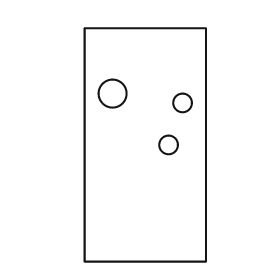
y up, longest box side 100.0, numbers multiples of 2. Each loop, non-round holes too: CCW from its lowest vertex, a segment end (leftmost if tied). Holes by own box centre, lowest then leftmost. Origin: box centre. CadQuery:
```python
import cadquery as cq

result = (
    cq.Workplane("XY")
    .moveTo(-26.0, -50.0)
    .lineTo(26.0, -50.0)
    .lineTo(26.0, 50.0)
    .lineTo(-26.0, 50.0)
    .close()
    .moveTo(10.0, 0.0)
    .circle(4.0)
    .moveTo(16.0, 18.0)
    .circle(4.0)
    .moveTo(-14.0, 22.0)
    .circle(6.0)
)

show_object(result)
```